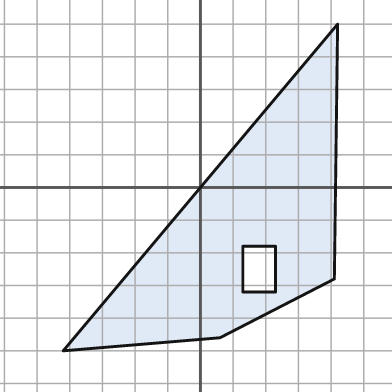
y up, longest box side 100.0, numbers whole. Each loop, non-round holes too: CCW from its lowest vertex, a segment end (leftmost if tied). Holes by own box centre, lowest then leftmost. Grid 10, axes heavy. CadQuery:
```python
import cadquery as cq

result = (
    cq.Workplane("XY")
    .moveTo(-42.0, -50.0)
    .lineTo(6.0, -46.0)
    .lineTo(41.0, -28.0)
    .lineTo(42.0, 50.0)
    .close()
    .moveTo(13.0, -32.0)
    .lineTo(23.0, -32.0)
    .lineTo(23.0, -18.0)
    .lineTo(13.0, -18.0)
    .close()
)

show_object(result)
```